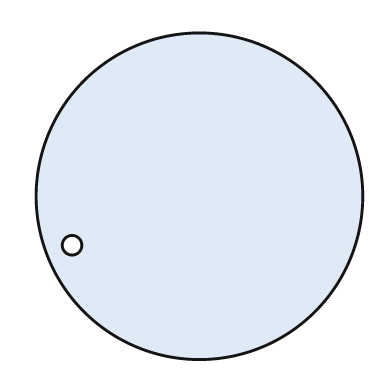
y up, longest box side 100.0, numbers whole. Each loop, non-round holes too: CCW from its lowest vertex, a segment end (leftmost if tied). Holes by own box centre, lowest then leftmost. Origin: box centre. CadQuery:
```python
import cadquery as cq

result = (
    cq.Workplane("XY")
    .moveTo(0.0, 0.0)
    .circle(50.0)
    .moveTo(-39.0, -15.0)
    .circle(3.0)
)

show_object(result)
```